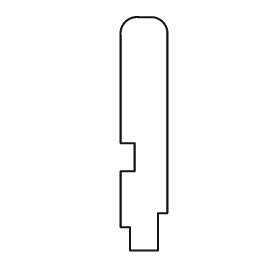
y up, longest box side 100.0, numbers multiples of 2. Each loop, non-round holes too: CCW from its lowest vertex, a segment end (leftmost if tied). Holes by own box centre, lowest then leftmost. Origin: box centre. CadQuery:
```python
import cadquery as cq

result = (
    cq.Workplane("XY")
    .moveTo(-6.0, -50.0)
    .lineTo(6.0, -50.0)
    .lineTo(6.0, -34.0)
    .lineTo(10.0, -34.0)
    .lineTo(10.0, 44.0)
    .threePointArc((8.0, 48.0), (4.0, 50.0))
    .lineTo(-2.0, 50.0)
    .threePointArc((-8.0, 48.0), (-10.0, 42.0))
    .lineTo(-10.0, -4.0)
    .lineTo(-4.0, -4.0)
    .lineTo(-4.0, -16.0)
    .lineTo(-10.0, -16.0)
    .lineTo(-10.0, -40.0)
    .lineTo(-6.0, -40.0)
    .close()
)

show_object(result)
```